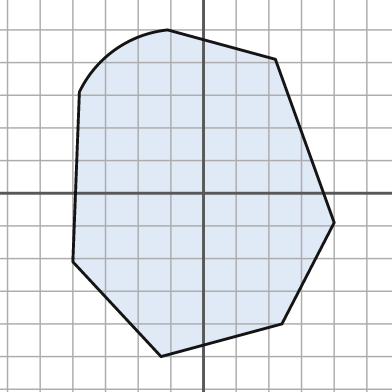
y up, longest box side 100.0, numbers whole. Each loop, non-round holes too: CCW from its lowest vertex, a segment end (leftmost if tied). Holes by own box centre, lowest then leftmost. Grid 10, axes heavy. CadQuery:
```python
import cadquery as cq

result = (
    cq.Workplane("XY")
    .moveTo(-13.0, -50.0)
    .lineTo(24.0, -40.0)
    .lineTo(40.0, -9.0)
    .lineTo(22.0, 41.0)
    .lineTo(-11.0, 50.0)
    .threePointArc((-27.0, 44.0), (-38.0, 31.0))
    .lineTo(-40.0, -21.0)
    .close()
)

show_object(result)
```